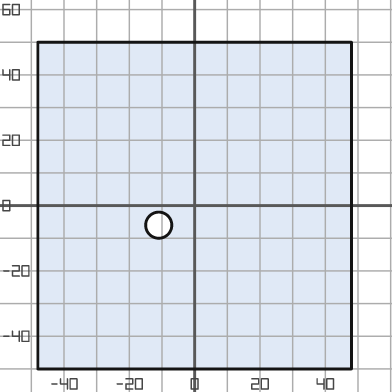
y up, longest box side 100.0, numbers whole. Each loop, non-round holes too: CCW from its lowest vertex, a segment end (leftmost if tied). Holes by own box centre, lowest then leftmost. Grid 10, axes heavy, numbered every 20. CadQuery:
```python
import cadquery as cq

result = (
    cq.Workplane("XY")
    .moveTo(-48.0, -50.0)
    .lineTo(48.0, -50.0)
    .lineTo(48.0, 50.0)
    .lineTo(-48.0, 50.0)
    .close()
    .moveTo(-11.0, -6.0)
    .circle(4.0)
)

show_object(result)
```